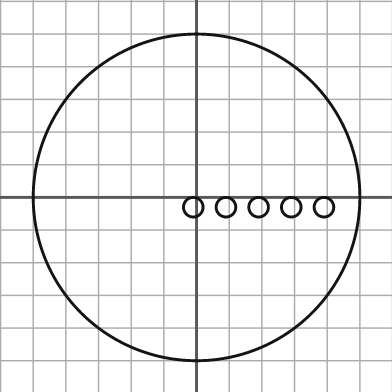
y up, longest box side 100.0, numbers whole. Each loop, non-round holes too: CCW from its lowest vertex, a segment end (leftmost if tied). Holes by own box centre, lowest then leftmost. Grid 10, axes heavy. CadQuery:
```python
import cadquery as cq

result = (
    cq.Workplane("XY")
    .moveTo(0.0, 0.0)
    .circle(50.0)
    .moveTo(-1.0, -3.0)
    .circle(3.0)
    .moveTo(9.0, -3.0)
    .circle(3.0)
    .moveTo(19.0, -3.0)
    .circle(3.0)
    .moveTo(29.0, -3.0)
    .circle(3.0)
    .moveTo(39.0, -3.0)
    .circle(3.0)
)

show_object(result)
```